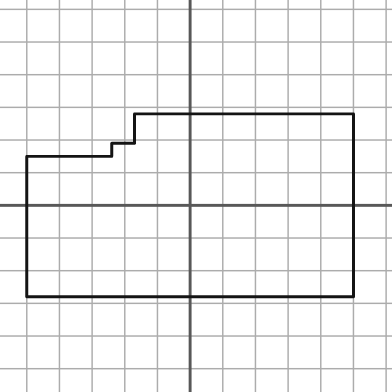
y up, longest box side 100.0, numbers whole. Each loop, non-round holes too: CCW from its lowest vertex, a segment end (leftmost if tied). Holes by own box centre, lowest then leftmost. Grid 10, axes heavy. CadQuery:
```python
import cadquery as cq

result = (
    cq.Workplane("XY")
    .moveTo(-50.0, -28.0)
    .lineTo(50.0, -28.0)
    .lineTo(50.0, 28.0)
    .lineTo(-17.0, 28.0)
    .lineTo(-17.0, 19.0)
    .lineTo(-24.0, 19.0)
    .lineTo(-24.0, 15.0)
    .lineTo(-50.0, 15.0)
    .close()
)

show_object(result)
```